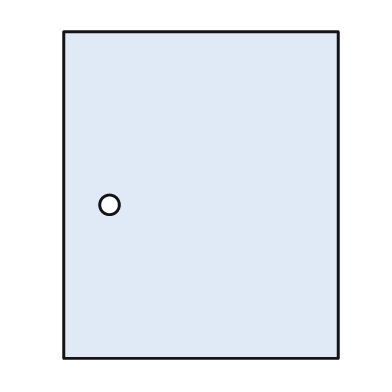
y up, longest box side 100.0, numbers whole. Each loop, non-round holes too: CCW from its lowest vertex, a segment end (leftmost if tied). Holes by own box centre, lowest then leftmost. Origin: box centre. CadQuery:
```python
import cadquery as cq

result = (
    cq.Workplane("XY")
    .moveTo(-42.0, -50.0)
    .lineTo(42.0, -50.0)
    .lineTo(42.0, 50.0)
    .lineTo(-42.0, 50.0)
    .close()
    .moveTo(-28.0, -3.0)
    .circle(3.0)
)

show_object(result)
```